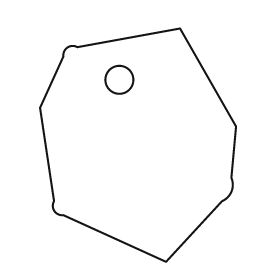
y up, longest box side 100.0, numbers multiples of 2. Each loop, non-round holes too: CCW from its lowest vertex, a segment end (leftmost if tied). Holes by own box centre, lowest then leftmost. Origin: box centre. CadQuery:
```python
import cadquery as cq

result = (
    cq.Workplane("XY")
    .moveTo(12.0, -50.0)
    .lineTo(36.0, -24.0)
    .threePointArc((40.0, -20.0), (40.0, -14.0))
    .lineTo(42.0, 8.0)
    .lineTo(18.0, 50.0)
    .lineTo(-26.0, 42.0)
    .threePointArc((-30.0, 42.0), (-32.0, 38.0))
    .lineTo(-42.0, 16.0)
    .lineTo(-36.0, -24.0)
    .threePointArc((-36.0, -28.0), (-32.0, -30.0))
    .close()
    .moveTo(-8.0, 28.0)
    .circle(6.0)
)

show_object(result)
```